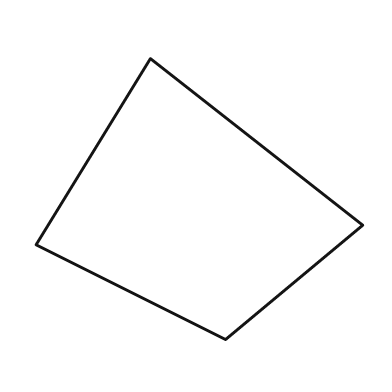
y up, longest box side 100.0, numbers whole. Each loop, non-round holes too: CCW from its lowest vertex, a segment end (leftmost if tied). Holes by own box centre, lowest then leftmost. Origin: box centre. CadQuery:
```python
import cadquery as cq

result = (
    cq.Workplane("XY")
    .moveTo(8.0, -43.0)
    .lineTo(50.0, -8.0)
    .lineTo(-15.0, 43.0)
    .lineTo(-50.0, -14.0)
    .close()
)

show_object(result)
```